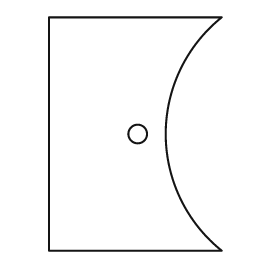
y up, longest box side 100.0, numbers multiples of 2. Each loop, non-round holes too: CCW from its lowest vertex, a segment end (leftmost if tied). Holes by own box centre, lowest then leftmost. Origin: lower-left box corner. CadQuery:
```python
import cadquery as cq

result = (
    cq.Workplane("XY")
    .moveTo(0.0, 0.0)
    .lineTo(74.0, 0.0)
    .threePointArc((50.0, 50.0), (74.0, 100.0))
    .lineTo(0.0, 100.0)
    .close()
    .moveTo(38.0, 50.0)
    .circle(4.0)
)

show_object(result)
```